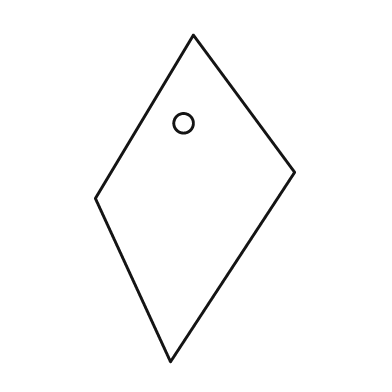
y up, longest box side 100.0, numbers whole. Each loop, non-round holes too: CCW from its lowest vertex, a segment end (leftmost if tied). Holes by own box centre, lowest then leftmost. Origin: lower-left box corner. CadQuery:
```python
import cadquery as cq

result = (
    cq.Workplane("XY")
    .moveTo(23.0, 0.0)
    .lineTo(61.0, 58.0)
    .lineTo(30.0, 100.0)
    .lineTo(0.0, 50.0)
    .close()
    .moveTo(27.0, 73.0)
    .circle(3.0)
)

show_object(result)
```